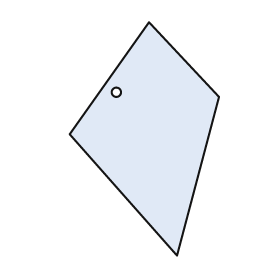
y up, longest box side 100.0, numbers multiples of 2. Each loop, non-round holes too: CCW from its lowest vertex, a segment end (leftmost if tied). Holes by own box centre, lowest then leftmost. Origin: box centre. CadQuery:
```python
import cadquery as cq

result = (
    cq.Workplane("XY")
    .moveTo(14.0, -50.0)
    .lineTo(32.0, 18.0)
    .lineTo(2.0, 50.0)
    .lineTo(-32.0, 2.0)
    .close()
    .moveTo(-12.0, 20.0)
    .circle(2.0)
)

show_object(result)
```